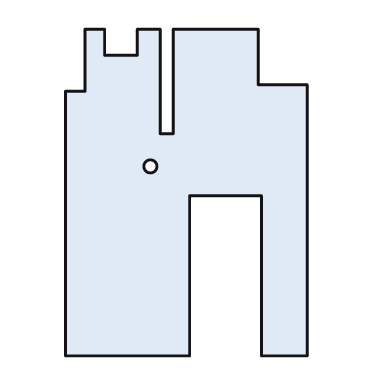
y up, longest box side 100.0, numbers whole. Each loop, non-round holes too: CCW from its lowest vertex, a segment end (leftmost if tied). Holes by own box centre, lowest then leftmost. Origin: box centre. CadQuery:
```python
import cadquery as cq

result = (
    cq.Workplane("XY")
    .moveTo(-37.0, -50.0)
    .lineTo(1.0, -50.0)
    .lineTo(1.0, -1.0)
    .lineTo(23.0, -1.0)
    .lineTo(23.0, -50.0)
    .lineTo(37.0, -50.0)
    .lineTo(37.0, 33.0)
    .lineTo(22.0, 33.0)
    .lineTo(22.0, 50.0)
    .lineTo(-4.0, 50.0)
    .lineTo(-4.0, 18.0)
    .lineTo(-8.0, 18.0)
    .lineTo(-8.0, 50.0)
    .lineTo(-15.0, 50.0)
    .lineTo(-15.0, 42.0)
    .lineTo(-25.0, 42.0)
    .lineTo(-25.0, 50.0)
    .lineTo(-31.0, 50.0)
    .lineTo(-31.0, 31.0)
    .lineTo(-37.0, 31.0)
    .close()
    .moveTo(-11.0, 8.0)
    .circle(2.0)
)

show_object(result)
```